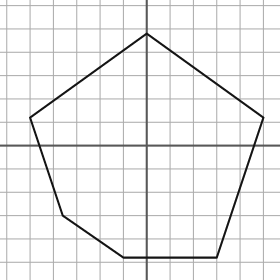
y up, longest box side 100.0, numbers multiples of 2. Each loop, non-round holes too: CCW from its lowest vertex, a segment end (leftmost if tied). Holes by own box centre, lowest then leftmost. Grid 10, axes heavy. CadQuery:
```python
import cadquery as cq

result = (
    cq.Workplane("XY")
    .moveTo(-10.0, -48.0)
    .lineTo(30.0, -48.0)
    .lineTo(50.0, 12.0)
    .lineTo(0.0, 48.0)
    .lineTo(-50.0, 12.0)
    .lineTo(-36.0, -30.0)
    .close()
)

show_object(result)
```